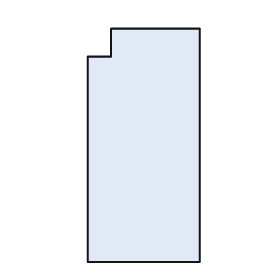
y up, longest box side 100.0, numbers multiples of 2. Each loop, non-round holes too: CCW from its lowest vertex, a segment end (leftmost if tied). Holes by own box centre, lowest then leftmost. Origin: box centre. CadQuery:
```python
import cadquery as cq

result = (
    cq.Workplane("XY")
    .moveTo(-24.0, -50.0)
    .lineTo(24.0, -50.0)
    .lineTo(24.0, 50.0)
    .lineTo(-14.0, 50.0)
    .lineTo(-14.0, 38.0)
    .lineTo(-24.0, 38.0)
    .close()
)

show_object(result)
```